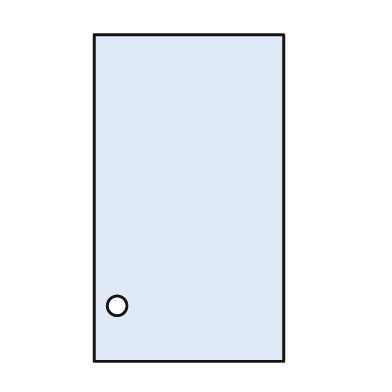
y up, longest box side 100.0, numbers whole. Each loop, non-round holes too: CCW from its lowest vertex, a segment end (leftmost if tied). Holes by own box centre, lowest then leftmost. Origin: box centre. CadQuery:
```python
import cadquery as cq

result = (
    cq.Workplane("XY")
    .moveTo(-29.0, -50.0)
    .lineTo(29.0, -50.0)
    .lineTo(29.0, 50.0)
    .lineTo(-29.0, 50.0)
    .close()
    .moveTo(-22.0, -33.0)
    .circle(3.0)
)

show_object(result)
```